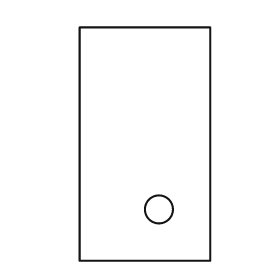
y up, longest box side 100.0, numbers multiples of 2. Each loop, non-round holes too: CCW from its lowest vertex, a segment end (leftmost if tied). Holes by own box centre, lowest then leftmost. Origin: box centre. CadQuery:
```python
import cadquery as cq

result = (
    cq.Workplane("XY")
    .moveTo(-28.0, -50.0)
    .lineTo(28.0, -50.0)
    .lineTo(28.0, 50.0)
    .lineTo(-28.0, 50.0)
    .close()
    .moveTo(6.0, -28.0)
    .circle(6.0)
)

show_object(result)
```